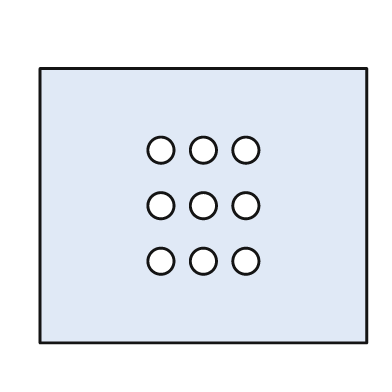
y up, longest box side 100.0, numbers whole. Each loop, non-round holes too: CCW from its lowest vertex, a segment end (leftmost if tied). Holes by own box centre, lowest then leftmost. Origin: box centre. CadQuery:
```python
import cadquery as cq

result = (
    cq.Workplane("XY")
    .moveTo(-50.0, -42.0)
    .lineTo(50.0, -42.0)
    .lineTo(50.0, 42.0)
    .lineTo(-50.0, 42.0)
    .close()
    .moveTo(-13.0, -17.0)
    .circle(4.0)
    .moveTo(0.0, -17.0)
    .circle(4.0)
    .moveTo(13.0, -17.0)
    .circle(4.0)
    .moveTo(-13.0, 0.0)
    .circle(4.0)
    .moveTo(0.0, 0.0)
    .circle(4.0)
    .moveTo(13.0, 0.0)
    .circle(4.0)
    .moveTo(-13.0, 17.0)
    .circle(4.0)
    .moveTo(0.0, 17.0)
    .circle(4.0)
    .moveTo(13.0, 17.0)
    .circle(4.0)
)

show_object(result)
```